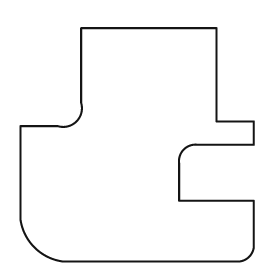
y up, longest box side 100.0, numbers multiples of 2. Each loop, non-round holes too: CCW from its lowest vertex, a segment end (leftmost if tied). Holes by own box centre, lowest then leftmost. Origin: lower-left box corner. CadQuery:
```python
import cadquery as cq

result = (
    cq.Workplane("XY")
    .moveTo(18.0, 0.0)
    .lineTo(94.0, 0.0)
    .threePointArc((98.0, 2.0), (100.0, 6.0))
    .lineTo(100.0, 26.0)
    .lineTo(68.0, 26.0)
    .lineTo(68.0, 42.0)
    .threePointArc((70.0, 48.0), (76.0, 50.0))
    .lineTo(100.0, 50.0)
    .lineTo(100.0, 60.0)
    .lineTo(84.0, 60.0)
    .lineTo(84.0, 100.0)
    .lineTo(26.0, 100.0)
    .lineTo(26.0, 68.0)
    .threePointArc((24.0, 60.0), (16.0, 58.0))
    .lineTo(0.0, 58.0)
    .lineTo(0.0, 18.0)
    .threePointArc((6.0, 6.0), (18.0, 0.0))
    .close()
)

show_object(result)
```